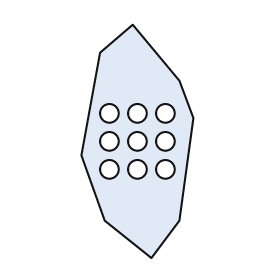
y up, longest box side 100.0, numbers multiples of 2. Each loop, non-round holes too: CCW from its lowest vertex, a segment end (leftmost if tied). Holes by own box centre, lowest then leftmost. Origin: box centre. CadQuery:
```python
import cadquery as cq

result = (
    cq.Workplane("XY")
    .moveTo(6.0, -50.0)
    .lineTo(18.0, -34.0)
    .lineTo(24.0, 10.0)
    .lineTo(18.0, 26.0)
    .lineTo(-2.0, 50.0)
    .lineTo(-16.0, 38.0)
    .lineTo(-24.0, -6.0)
    .lineTo(-14.0, -34.0)
    .close()
    .moveTo(-12.0, -12.0)
    .circle(4.0)
    .moveTo(0.0, -12.0)
    .circle(4.0)
    .moveTo(12.0, -12.0)
    .circle(4.0)
    .moveTo(-12.0, 0.0)
    .circle(4.0)
    .moveTo(0.0, 0.0)
    .circle(4.0)
    .moveTo(12.0, 0.0)
    .circle(4.0)
    .moveTo(-12.0, 12.0)
    .circle(4.0)
    .moveTo(0.0, 12.0)
    .circle(4.0)
    .moveTo(12.0, 12.0)
    .circle(4.0)
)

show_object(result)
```